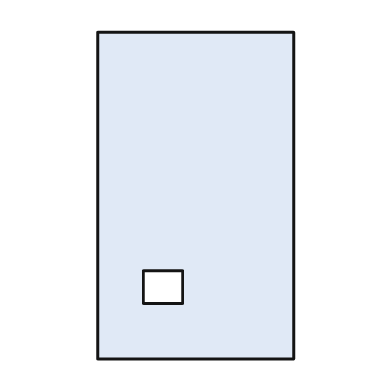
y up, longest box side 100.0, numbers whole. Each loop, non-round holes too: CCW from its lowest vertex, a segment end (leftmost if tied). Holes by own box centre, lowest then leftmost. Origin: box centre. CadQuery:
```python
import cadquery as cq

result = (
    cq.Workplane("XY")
    .moveTo(-30.0, -50.0)
    .lineTo(30.0, -50.0)
    .lineTo(30.0, 50.0)
    .lineTo(-30.0, 50.0)
    .close()
    .moveTo(-16.0, -33.0)
    .lineTo(-4.0, -33.0)
    .lineTo(-4.0, -23.0)
    .lineTo(-16.0, -23.0)
    .close()
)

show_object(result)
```